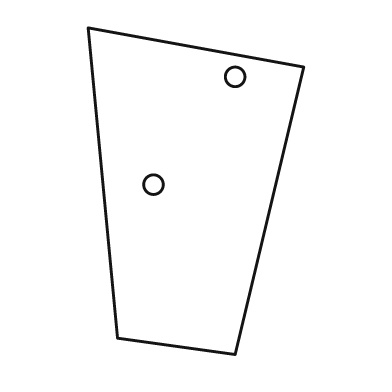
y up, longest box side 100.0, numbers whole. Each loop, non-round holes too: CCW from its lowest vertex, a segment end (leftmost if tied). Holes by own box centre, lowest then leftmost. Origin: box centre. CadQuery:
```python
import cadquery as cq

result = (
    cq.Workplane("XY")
    .moveTo(12.0, -50.0)
    .lineTo(33.0, 38.0)
    .lineTo(-33.0, 50.0)
    .lineTo(-24.0, -45.0)
    .close()
    .moveTo(-13.0, 2.0)
    .circle(3.0)
    .moveTo(12.0, 35.0)
    .circle(3.0)
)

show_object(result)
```